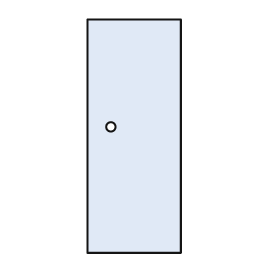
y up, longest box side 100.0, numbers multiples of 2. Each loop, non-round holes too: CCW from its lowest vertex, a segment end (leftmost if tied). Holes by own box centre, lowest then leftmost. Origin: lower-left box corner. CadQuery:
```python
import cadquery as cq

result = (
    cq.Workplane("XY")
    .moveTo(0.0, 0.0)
    .lineTo(40.0, 0.0)
    .lineTo(40.0, 100.0)
    .lineTo(0.0, 100.0)
    .close()
    .moveTo(10.0, 54.0)
    .circle(2.0)
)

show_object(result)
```